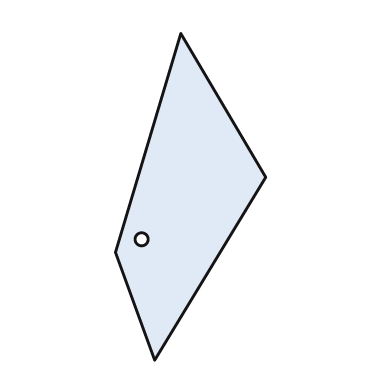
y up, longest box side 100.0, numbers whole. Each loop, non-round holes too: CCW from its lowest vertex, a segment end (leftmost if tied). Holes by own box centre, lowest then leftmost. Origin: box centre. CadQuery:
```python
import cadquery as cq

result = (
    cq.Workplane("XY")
    .moveTo(-11.0, -50.0)
    .lineTo(23.0, 6.0)
    .lineTo(-3.0, 50.0)
    .lineTo(-23.0, -17.0)
    .close()
    .moveTo(-15.0, -13.0)
    .circle(2.0)
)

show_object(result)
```